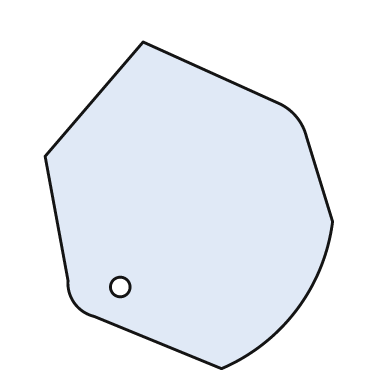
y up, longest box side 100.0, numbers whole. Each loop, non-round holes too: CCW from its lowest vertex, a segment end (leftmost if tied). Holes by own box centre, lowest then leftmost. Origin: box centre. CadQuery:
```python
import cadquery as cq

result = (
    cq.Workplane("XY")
    .moveTo(10.0, -50.0)
    .threePointArc((33.0, -32.0), (44.0, -5.0))
    .lineTo(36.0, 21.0)
    .threePointArc((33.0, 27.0), (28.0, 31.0))
    .lineTo(-14.0, 50.0)
    .lineTo(-44.0, 15.0)
    .lineTo(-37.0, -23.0)
    .threePointArc((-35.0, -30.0), (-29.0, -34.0))
    .close()
    .moveTo(-21.0, -25.0)
    .circle(3.0)
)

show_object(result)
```